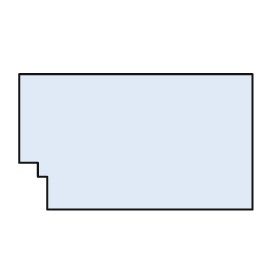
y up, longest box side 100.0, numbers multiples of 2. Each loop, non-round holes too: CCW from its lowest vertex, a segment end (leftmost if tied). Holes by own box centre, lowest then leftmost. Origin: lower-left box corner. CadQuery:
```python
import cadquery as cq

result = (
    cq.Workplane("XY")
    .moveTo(12.0, 0.0)
    .lineTo(100.0, 0.0)
    .lineTo(100.0, 58.0)
    .lineTo(0.0, 58.0)
    .lineTo(0.0, 20.0)
    .lineTo(8.0, 20.0)
    .lineTo(8.0, 14.0)
    .lineTo(12.0, 14.0)
    .close()
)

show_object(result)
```